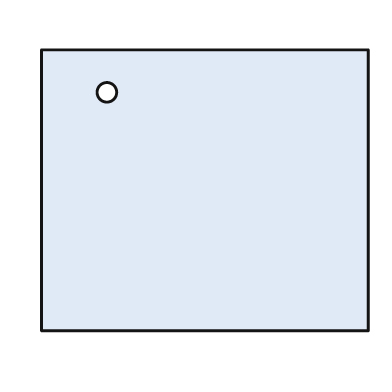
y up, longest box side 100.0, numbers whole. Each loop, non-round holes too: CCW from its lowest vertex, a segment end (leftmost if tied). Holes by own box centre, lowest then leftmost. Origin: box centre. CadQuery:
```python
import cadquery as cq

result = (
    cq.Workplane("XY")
    .moveTo(-50.0, -43.0)
    .lineTo(50.0, -43.0)
    .lineTo(50.0, 43.0)
    .lineTo(-50.0, 43.0)
    .close()
    .moveTo(-30.0, 30.0)
    .circle(3.0)
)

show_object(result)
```